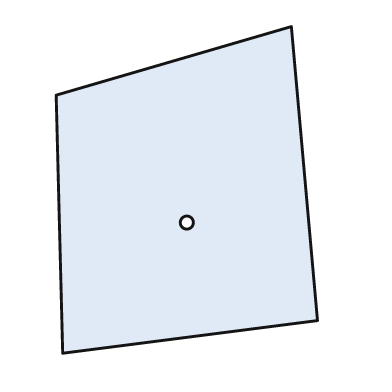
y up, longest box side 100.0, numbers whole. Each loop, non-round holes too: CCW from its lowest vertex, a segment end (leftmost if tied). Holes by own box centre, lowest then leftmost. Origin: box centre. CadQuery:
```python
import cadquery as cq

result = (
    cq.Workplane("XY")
    .moveTo(-38.0, -50.0)
    .lineTo(40.0, -40.0)
    .lineTo(32.0, 50.0)
    .lineTo(-40.0, 29.0)
    .close()
    .moveTo(0.0, -10.0)
    .circle(2.0)
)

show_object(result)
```